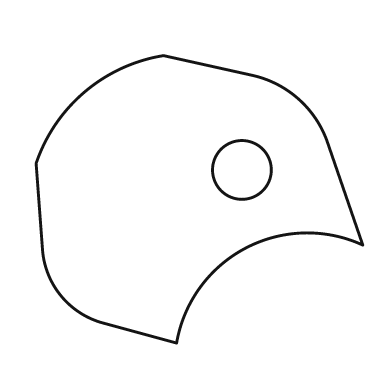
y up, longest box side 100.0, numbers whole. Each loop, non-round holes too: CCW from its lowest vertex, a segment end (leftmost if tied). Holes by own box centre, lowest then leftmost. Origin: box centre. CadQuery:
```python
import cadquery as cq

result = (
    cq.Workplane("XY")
    .moveTo(-7.0, -44.0)
    .threePointArc((14.0, -15.0), (50.0, -14.0))
    .lineTo(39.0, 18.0)
    .threePointArc((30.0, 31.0), (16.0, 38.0))
    .lineTo(-11.0, 44.0)
    .threePointArc((-35.0, 33.0), (-50.0, 11.0))
    .lineTo(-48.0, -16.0)
    .threePointArc((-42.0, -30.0), (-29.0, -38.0))
    .close()
    .moveTo(13.0, 9.0)
    .circle(9.0)
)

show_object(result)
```